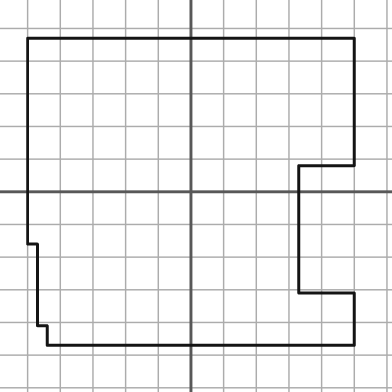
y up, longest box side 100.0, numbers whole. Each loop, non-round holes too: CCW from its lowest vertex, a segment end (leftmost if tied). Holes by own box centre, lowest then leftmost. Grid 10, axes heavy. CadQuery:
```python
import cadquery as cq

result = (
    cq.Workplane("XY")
    .moveTo(-44.0, -47.0)
    .lineTo(50.0, -47.0)
    .lineTo(50.0, -31.0)
    .lineTo(33.0, -31.0)
    .lineTo(33.0, 8.0)
    .lineTo(50.0, 8.0)
    .lineTo(50.0, 47.0)
    .lineTo(-50.0, 47.0)
    .lineTo(-50.0, -16.0)
    .lineTo(-47.0, -16.0)
    .lineTo(-47.0, -41.0)
    .lineTo(-44.0, -41.0)
    .close()
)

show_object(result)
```